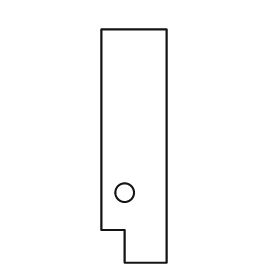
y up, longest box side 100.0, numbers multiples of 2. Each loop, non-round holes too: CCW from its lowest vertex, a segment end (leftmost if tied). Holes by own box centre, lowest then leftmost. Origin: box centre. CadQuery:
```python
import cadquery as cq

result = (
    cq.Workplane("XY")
    .moveTo(-4.0, -50.0)
    .lineTo(14.0, -50.0)
    .lineTo(14.0, 50.0)
    .lineTo(-14.0, 50.0)
    .lineTo(-14.0, -36.0)
    .lineTo(-4.0, -36.0)
    .close()
    .moveTo(-4.0, -20.0)
    .circle(4.0)
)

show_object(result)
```